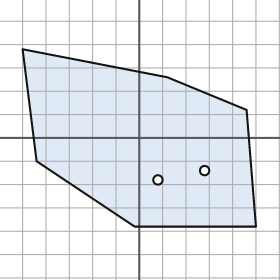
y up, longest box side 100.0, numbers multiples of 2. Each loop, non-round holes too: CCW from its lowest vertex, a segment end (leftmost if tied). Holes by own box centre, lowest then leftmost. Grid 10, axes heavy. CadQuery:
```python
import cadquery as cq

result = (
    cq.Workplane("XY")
    .moveTo(-2.0, -38.0)
    .lineTo(50.0, -38.0)
    .lineTo(46.0, 12.0)
    .lineTo(12.0, 26.0)
    .lineTo(-50.0, 38.0)
    .lineTo(-44.0, -10.0)
    .close()
    .moveTo(8.0, -18.0)
    .circle(2.0)
    .moveTo(28.0, -14.0)
    .circle(2.0)
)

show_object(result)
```